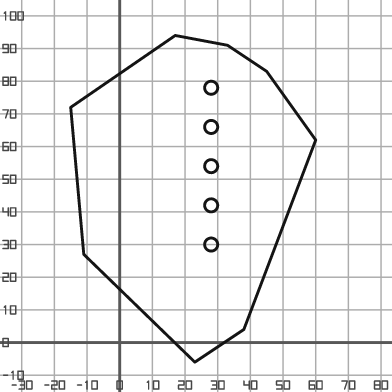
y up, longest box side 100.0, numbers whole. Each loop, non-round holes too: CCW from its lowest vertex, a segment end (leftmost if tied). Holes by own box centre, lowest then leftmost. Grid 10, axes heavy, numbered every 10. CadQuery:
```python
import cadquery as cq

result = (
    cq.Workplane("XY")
    .moveTo(23.0, -6.0)
    .lineTo(38.0, 4.0)
    .lineTo(60.0, 62.0)
    .lineTo(45.0, 83.0)
    .lineTo(33.0, 91.0)
    .lineTo(17.0, 94.0)
    .lineTo(-15.0, 72.0)
    .lineTo(-11.0, 27.0)
    .close()
    .moveTo(28.0, 30.0)
    .circle(2.0)
    .moveTo(28.0, 42.0)
    .circle(2.0)
    .moveTo(28.0, 54.0)
    .circle(2.0)
    .moveTo(28.0, 66.0)
    .circle(2.0)
    .moveTo(28.0, 78.0)
    .circle(2.0)
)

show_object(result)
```